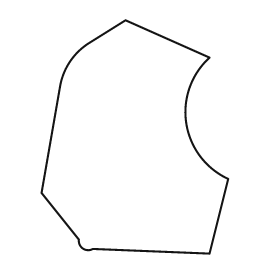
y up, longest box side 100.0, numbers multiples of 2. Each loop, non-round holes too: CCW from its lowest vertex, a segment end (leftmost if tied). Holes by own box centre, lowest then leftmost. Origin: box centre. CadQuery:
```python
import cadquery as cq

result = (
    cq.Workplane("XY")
    .moveTo(32.0, -50.0)
    .lineTo(40.0, -18.0)
    .threePointArc((22.0, 6.0), (32.0, 34.0))
    .lineTo(-4.0, 50.0)
    .lineTo(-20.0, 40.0)
    .threePointArc((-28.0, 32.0), (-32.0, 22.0))
    .lineTo(-40.0, -24.0)
    .lineTo(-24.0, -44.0)
    .threePointArc((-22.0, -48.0), (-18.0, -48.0))
    .close()
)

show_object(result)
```